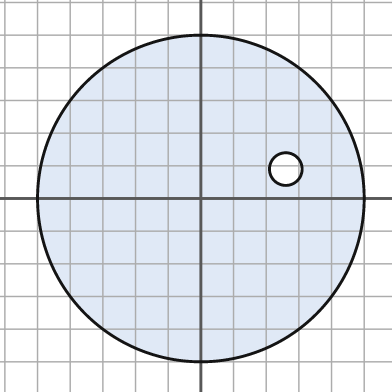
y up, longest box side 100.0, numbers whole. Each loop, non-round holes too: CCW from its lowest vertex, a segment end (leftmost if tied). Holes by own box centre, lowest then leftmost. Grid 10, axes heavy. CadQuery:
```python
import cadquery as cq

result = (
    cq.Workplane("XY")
    .moveTo(0.0, 0.0)
    .circle(50.0)
    .moveTo(26.0, 9.0)
    .circle(5.0)
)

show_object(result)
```